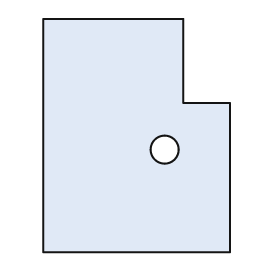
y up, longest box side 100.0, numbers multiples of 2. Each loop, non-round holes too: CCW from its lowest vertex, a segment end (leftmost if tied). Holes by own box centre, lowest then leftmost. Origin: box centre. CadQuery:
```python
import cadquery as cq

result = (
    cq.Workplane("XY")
    .moveTo(-40.0, -50.0)
    .lineTo(40.0, -50.0)
    .lineTo(40.0, 14.0)
    .lineTo(20.0, 14.0)
    .lineTo(20.0, 50.0)
    .lineTo(-40.0, 50.0)
    .close()
    .moveTo(12.0, -6.0)
    .circle(6.0)
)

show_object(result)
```